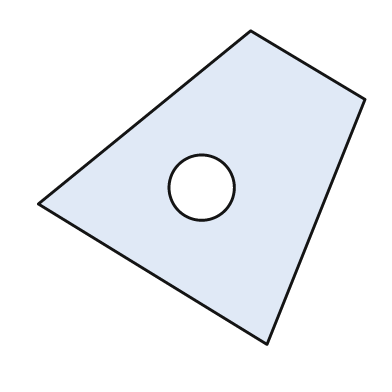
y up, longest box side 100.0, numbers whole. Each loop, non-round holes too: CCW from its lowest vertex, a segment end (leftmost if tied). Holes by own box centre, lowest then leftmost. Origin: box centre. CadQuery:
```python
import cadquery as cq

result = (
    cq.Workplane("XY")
    .moveTo(20.0, -48.0)
    .lineTo(50.0, 27.0)
    .lineTo(15.0, 48.0)
    .lineTo(-50.0, -5.0)
    .close()
    .moveTo(0.0, 0.0)
    .circle(10.0)
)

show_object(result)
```